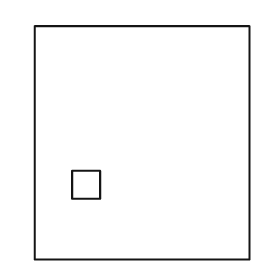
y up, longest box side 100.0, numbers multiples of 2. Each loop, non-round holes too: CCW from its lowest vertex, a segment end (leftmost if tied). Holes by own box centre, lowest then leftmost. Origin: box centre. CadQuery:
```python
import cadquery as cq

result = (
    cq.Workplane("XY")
    .moveTo(-46.0, -50.0)
    .lineTo(46.0, -50.0)
    .lineTo(46.0, 50.0)
    .lineTo(-46.0, 50.0)
    .close()
    .moveTo(-30.0, -24.0)
    .lineTo(-18.0, -24.0)
    .lineTo(-18.0, -12.0)
    .lineTo(-30.0, -12.0)
    .close()
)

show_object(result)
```